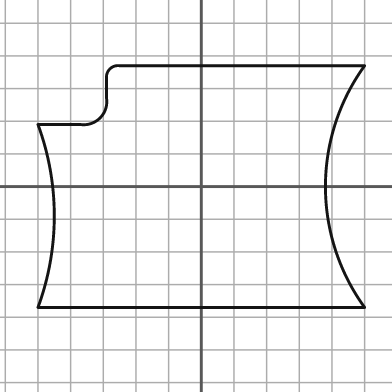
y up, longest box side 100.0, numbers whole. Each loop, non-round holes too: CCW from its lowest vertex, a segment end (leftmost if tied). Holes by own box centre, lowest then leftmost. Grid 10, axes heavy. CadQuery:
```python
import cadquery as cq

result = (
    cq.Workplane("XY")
    .moveTo(-50.0, -37.0)
    .lineTo(50.0, -37.0)
    .threePointArc((38.0, 0.0), (50.0, 37.0))
    .lineTo(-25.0, 37.0)
    .threePointArc((-28.0, 36.0), (-29.0, 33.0))
    .lineTo(-29.0, 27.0)
    .threePointArc((-31.0, 21.0), (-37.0, 19.0))
    .lineTo(-50.0, 19.0)
    .threePointArc((-45.0, -9.0), (-50.0, -37.0))
    .close()
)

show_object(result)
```